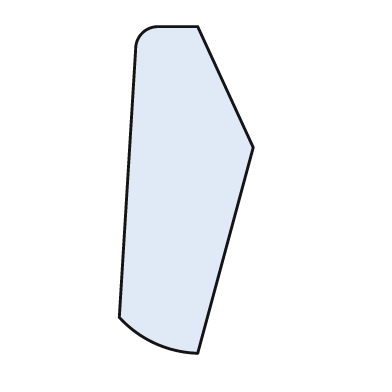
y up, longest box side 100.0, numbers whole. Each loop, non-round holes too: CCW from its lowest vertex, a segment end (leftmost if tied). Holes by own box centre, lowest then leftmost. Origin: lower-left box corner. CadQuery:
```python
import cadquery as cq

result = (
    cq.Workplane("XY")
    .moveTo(24.0, 0.0)
    .lineTo(41.0, 63.0)
    .lineTo(24.0, 100.0)
    .lineTo(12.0, 100.0)
    .threePointArc((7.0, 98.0), (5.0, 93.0))
    .lineTo(0.0, 11.0)
    .threePointArc((11.0, 3.0), (24.0, 0.0))
    .close()
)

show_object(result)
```